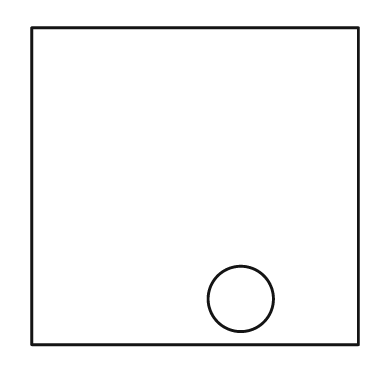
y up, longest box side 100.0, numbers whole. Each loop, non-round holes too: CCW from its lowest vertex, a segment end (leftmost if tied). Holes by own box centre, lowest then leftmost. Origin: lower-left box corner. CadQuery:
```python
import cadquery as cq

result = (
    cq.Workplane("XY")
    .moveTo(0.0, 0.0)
    .lineTo(100.0, 0.0)
    .lineTo(100.0, 97.0)
    .lineTo(0.0, 97.0)
    .close()
    .moveTo(64.0, 14.0)
    .circle(10.0)
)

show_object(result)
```